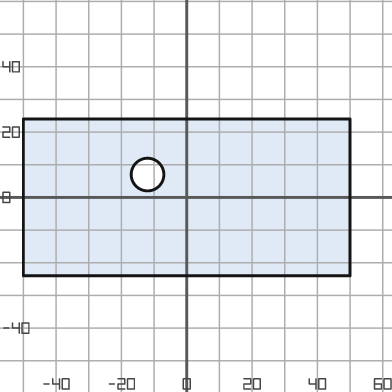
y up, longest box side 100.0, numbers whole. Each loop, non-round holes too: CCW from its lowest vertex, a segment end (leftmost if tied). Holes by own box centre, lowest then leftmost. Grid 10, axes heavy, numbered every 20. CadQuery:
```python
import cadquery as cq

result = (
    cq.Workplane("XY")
    .moveTo(-50.0, -24.0)
    .lineTo(50.0, -24.0)
    .lineTo(50.0, 24.0)
    .lineTo(-50.0, 24.0)
    .close()
    .moveTo(-12.0, 7.0)
    .circle(5.0)
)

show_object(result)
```